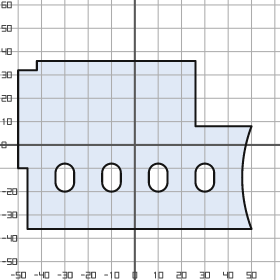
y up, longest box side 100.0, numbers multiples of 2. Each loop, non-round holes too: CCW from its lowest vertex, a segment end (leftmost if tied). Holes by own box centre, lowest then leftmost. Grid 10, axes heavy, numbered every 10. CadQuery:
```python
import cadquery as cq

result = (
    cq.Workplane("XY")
    .moveTo(-46.0, -36.0)
    .lineTo(50.0, -36.0)
    .threePointArc((46.0, -14.0), (50.0, 8.0))
    .lineTo(26.0, 8.0)
    .lineTo(26.0, 36.0)
    .lineTo(-42.0, 36.0)
    .lineTo(-42.0, 32.0)
    .lineTo(-50.0, 32.0)
    .lineTo(-50.0, -10.0)
    .lineTo(-46.0, -10.0)
    .close()
    .moveTo(-34.0, -16.0)
    .threePointArc((-30.0, -20.0), (-26.0, -16.0))
    .lineTo(-26.0, -12.0)
    .threePointArc((-30.0, -8.0), (-34.0, -12.0))
    .close()
    .moveTo(-14.0, -16.0)
    .threePointArc((-10.0, -20.0), (-6.0, -16.0))
    .lineTo(-6.0, -12.0)
    .threePointArc((-10.0, -8.0), (-14.0, -12.0))
    .close()
    .moveTo(6.0, -16.0)
    .threePointArc((10.0, -20.0), (14.0, -16.0))
    .lineTo(14.0, -12.0)
    .threePointArc((10.0, -8.0), (6.0, -12.0))
    .close()
    .moveTo(26.0, -16.0)
    .threePointArc((30.0, -20.0), (34.0, -16.0))
    .lineTo(34.0, -12.0)
    .threePointArc((30.0, -8.0), (26.0, -12.0))
    .close()
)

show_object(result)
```